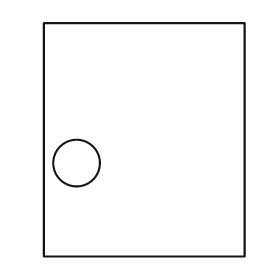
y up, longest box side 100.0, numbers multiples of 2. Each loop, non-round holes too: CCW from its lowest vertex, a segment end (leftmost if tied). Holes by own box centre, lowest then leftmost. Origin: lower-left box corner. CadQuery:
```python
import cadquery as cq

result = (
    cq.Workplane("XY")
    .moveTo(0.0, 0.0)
    .lineTo(86.0, 0.0)
    .lineTo(86.0, 100.0)
    .lineTo(0.0, 100.0)
    .close()
    .moveTo(14.0, 40.0)
    .circle(10.0)
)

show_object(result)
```